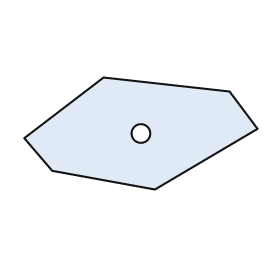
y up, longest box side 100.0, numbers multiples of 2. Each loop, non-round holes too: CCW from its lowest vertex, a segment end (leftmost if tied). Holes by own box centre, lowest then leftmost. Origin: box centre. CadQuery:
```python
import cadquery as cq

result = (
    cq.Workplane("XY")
    .moveTo(6.0, -24.0)
    .lineTo(50.0, 2.0)
    .lineTo(38.0, 18.0)
    .lineTo(-16.0, 24.0)
    .lineTo(-50.0, -2.0)
    .lineTo(-38.0, -16.0)
    .close()
    .moveTo(0.0, 0.0)
    .circle(4.0)
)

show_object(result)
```